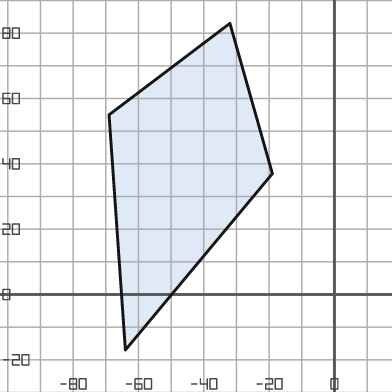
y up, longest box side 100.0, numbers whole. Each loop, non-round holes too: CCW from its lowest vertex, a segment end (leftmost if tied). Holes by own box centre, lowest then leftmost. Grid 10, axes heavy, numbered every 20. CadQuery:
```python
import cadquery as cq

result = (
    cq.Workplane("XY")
    .moveTo(-64.0, -17.0)
    .lineTo(-19.0, 37.0)
    .lineTo(-32.0, 83.0)
    .lineTo(-69.0, 55.0)
    .close()
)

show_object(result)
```